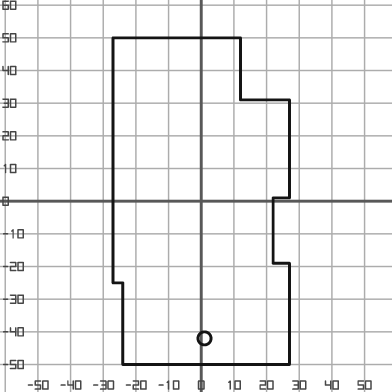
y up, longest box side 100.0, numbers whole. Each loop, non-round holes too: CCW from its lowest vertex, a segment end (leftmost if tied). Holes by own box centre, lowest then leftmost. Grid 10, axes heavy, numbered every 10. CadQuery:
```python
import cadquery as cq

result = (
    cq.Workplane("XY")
    .moveTo(-24.0, -50.0)
    .lineTo(27.0, -50.0)
    .lineTo(27.0, -19.0)
    .lineTo(22.0, -19.0)
    .lineTo(22.0, 1.0)
    .lineTo(27.0, 1.0)
    .lineTo(27.0, 31.0)
    .lineTo(12.0, 31.0)
    .lineTo(12.0, 50.0)
    .lineTo(-27.0, 50.0)
    .lineTo(-27.0, -25.0)
    .lineTo(-24.0, -25.0)
    .close()
    .moveTo(1.0, -42.0)
    .circle(2.0)
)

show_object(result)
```